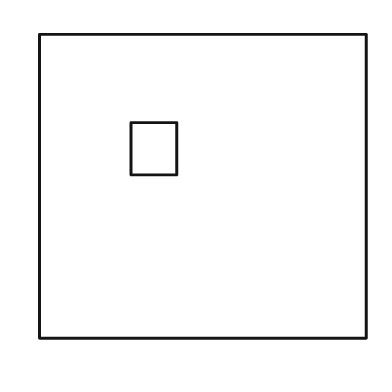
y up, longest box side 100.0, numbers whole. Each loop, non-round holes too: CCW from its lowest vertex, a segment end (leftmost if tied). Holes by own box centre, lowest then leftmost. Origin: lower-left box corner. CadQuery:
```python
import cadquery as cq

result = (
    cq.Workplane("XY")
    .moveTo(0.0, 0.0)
    .lineTo(100.0, 0.0)
    .lineTo(100.0, 93.0)
    .lineTo(0.0, 93.0)
    .close()
    .moveTo(28.0, 50.0)
    .lineTo(42.0, 50.0)
    .lineTo(42.0, 66.0)
    .lineTo(28.0, 66.0)
    .close()
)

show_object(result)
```